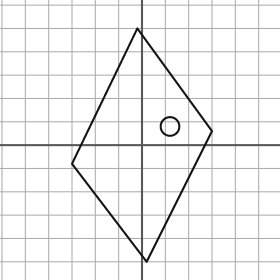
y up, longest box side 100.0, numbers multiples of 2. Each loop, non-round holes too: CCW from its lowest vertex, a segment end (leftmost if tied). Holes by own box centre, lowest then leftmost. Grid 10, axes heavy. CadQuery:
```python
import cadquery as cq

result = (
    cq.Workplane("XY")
    .moveTo(2.0, -50.0)
    .lineTo(30.0, 6.0)
    .lineTo(-2.0, 50.0)
    .lineTo(-30.0, -8.0)
    .close()
    .moveTo(12.0, 8.0)
    .circle(4.0)
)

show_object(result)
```